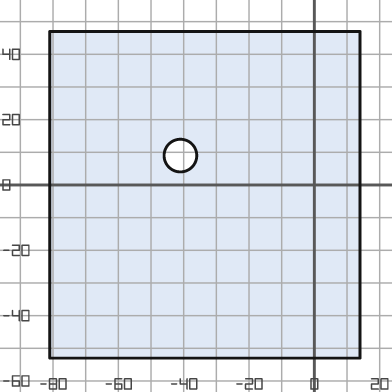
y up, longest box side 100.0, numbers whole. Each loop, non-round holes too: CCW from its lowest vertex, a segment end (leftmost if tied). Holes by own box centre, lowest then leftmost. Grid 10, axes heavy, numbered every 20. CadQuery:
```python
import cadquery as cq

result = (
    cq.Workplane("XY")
    .moveTo(-81.0, -53.0)
    .lineTo(14.0, -53.0)
    .lineTo(14.0, 47.0)
    .lineTo(-81.0, 47.0)
    .close()
    .moveTo(-41.0, 9.0)
    .circle(5.0)
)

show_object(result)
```